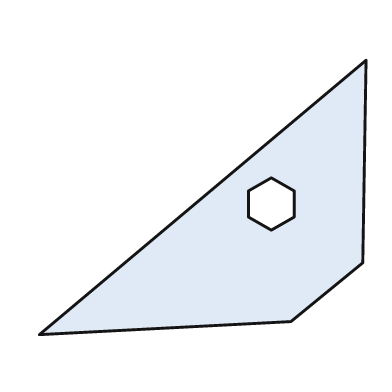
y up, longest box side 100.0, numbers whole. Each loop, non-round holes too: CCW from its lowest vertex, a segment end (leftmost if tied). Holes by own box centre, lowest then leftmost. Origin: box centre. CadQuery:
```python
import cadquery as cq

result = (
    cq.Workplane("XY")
    .moveTo(-50.0, -42.0)
    .lineTo(27.0, -38.0)
    .lineTo(49.0, -20.0)
    .lineTo(50.0, 42.0)
    .close()
    .moveTo(21.0, -10.0)
    .lineTo(28.0, -6.0)
    .lineTo(28.0, 2.0)
    .lineTo(21.0, 6.0)
    .lineTo(14.0, 2.0)
    .lineTo(14.0, -6.0)
    .close()
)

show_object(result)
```